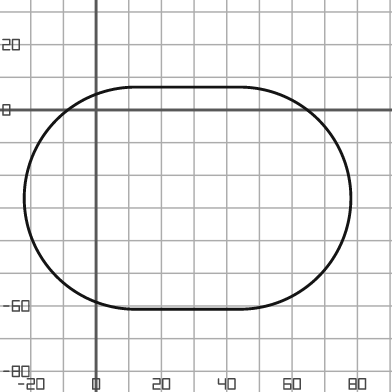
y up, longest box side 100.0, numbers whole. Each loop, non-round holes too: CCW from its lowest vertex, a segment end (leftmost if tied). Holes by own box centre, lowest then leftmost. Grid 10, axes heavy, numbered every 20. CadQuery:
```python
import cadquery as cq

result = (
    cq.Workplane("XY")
    .moveTo(12.0, -61.0)
    .lineTo(44.0, -61.0)
    .threePointArc((78.0, -27.0), (44.0, 7.0))
    .lineTo(12.0, 7.0)
    .threePointArc((-22.0, -27.0), (12.0, -61.0))
    .close()
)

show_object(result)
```